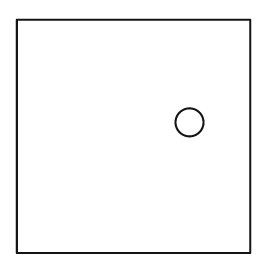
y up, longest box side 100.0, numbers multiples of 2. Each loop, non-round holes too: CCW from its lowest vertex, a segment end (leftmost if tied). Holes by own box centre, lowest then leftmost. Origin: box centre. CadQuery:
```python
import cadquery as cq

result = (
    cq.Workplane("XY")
    .moveTo(-50.0, -50.0)
    .lineTo(50.0, -50.0)
    .lineTo(50.0, 50.0)
    .lineTo(-50.0, 50.0)
    .close()
    .moveTo(24.0, 6.0)
    .circle(6.0)
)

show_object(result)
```